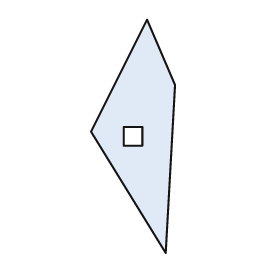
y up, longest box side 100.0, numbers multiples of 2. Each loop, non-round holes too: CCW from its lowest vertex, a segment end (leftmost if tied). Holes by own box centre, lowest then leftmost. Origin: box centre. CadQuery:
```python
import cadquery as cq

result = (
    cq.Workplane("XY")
    .moveTo(14.0, -50.0)
    .lineTo(18.0, 22.0)
    .lineTo(6.0, 50.0)
    .lineTo(-18.0, 2.0)
    .close()
    .moveTo(-4.0, -4.0)
    .lineTo(4.0, -4.0)
    .lineTo(4.0, 4.0)
    .lineTo(-4.0, 4.0)
    .close()
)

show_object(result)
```